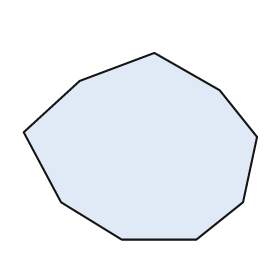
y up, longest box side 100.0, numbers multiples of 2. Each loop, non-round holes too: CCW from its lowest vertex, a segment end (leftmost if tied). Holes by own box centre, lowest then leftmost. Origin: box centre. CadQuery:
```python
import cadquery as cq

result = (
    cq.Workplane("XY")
    .moveTo(-8.0, -40.0)
    .lineTo(24.0, -40.0)
    .lineTo(44.0, -24.0)
    .lineTo(50.0, 4.0)
    .lineTo(34.0, 24.0)
    .lineTo(6.0, 40.0)
    .lineTo(-26.0, 28.0)
    .lineTo(-50.0, 6.0)
    .lineTo(-34.0, -24.0)
    .close()
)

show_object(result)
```